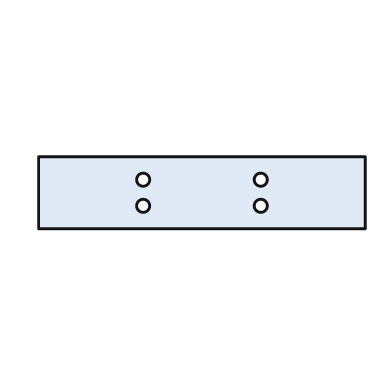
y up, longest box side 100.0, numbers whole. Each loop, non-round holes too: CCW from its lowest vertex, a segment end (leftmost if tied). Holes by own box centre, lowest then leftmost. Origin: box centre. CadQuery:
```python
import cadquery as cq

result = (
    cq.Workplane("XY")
    .moveTo(-50.0, -11.0)
    .lineTo(50.0, -11.0)
    .lineTo(50.0, 11.0)
    .lineTo(-50.0, 11.0)
    .close()
    .moveTo(-18.0, -4.0)
    .circle(2.0)
    .moveTo(18.0, -4.0)
    .circle(2.0)
    .moveTo(-18.0, 4.0)
    .circle(2.0)
    .moveTo(18.0, 4.0)
    .circle(2.0)
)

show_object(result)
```